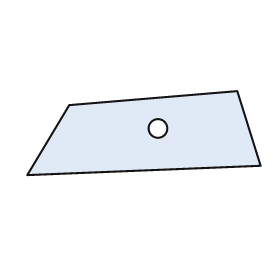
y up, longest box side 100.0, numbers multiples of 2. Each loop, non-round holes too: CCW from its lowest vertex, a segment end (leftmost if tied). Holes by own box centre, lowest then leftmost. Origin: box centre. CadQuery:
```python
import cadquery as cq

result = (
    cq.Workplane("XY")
    .moveTo(-50.0, -18.0)
    .lineTo(50.0, -14.0)
    .lineTo(40.0, 18.0)
    .lineTo(-32.0, 12.0)
    .close()
    .moveTo(6.0, 2.0)
    .circle(4.0)
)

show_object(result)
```